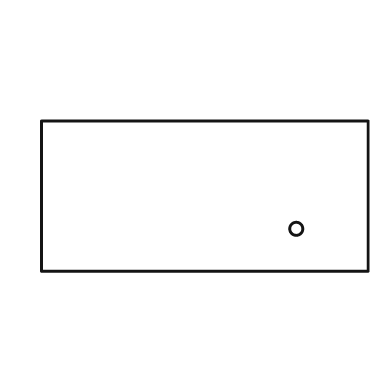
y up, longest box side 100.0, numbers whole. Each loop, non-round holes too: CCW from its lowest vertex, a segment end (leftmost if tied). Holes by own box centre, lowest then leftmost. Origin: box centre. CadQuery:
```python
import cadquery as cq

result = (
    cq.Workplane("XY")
    .moveTo(-50.0, -23.0)
    .lineTo(50.0, -23.0)
    .lineTo(50.0, 23.0)
    .lineTo(-50.0, 23.0)
    .close()
    .moveTo(28.0, -10.0)
    .circle(2.0)
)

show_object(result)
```